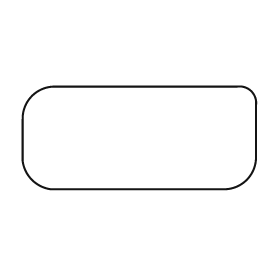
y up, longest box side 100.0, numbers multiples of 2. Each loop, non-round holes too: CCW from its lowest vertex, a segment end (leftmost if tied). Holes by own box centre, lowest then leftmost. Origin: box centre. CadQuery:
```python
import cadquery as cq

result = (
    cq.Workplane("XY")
    .moveTo(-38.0, -22.0)
    .lineTo(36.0, -22.0)
    .threePointArc((46.0, -18.0), (50.0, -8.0))
    .lineTo(50.0, 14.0)
    .threePointArc((48.0, 20.0), (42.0, 22.0))
    .lineTo(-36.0, 22.0)
    .threePointArc((-46.0, 18.0), (-50.0, 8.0))
    .lineTo(-50.0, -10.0)
    .threePointArc((-46.0, -18.0), (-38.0, -22.0))
    .close()
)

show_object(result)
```